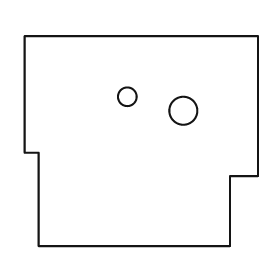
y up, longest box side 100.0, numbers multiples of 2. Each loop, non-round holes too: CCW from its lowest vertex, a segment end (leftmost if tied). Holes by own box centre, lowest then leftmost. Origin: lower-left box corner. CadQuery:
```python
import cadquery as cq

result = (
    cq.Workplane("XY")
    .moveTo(6.0, 0.0)
    .lineTo(88.0, 0.0)
    .lineTo(88.0, 30.0)
    .lineTo(100.0, 30.0)
    .lineTo(100.0, 90.0)
    .lineTo(0.0, 90.0)
    .lineTo(0.0, 40.0)
    .lineTo(6.0, 40.0)
    .close()
    .moveTo(68.0, 58.0)
    .circle(6.0)
    .moveTo(44.0, 64.0)
    .circle(4.0)
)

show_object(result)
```